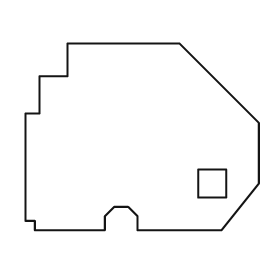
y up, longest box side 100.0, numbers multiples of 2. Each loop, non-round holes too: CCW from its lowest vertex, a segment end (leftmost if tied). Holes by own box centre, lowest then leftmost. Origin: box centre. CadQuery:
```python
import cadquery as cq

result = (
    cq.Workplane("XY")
    .moveTo(-46.0, -40.0)
    .lineTo(-16.0, -40.0)
    .lineTo(-16.0, -34.0)
    .lineTo(-12.0, -30.0)
    .lineTo(-6.0, -30.0)
    .lineTo(-2.0, -34.0)
    .lineTo(-2.0, -40.0)
    .lineTo(34.0, -40.0)
    .lineTo(50.0, -20.0)
    .lineTo(50.0, 6.0)
    .lineTo(16.0, 40.0)
    .lineTo(-32.0, 40.0)
    .lineTo(-32.0, 26.0)
    .lineTo(-44.0, 26.0)
    .lineTo(-44.0, 10.0)
    .lineTo(-50.0, 10.0)
    .lineTo(-50.0, -36.0)
    .lineTo(-46.0, -36.0)
    .close()
    .moveTo(24.0, -26.0)
    .lineTo(36.0, -26.0)
    .lineTo(36.0, -14.0)
    .lineTo(24.0, -14.0)
    .close()
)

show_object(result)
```